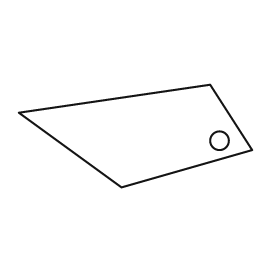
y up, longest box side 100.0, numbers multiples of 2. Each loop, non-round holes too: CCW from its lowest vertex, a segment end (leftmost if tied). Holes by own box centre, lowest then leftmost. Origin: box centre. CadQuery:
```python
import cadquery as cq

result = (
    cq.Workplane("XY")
    .moveTo(-6.0, -22.0)
    .lineTo(50.0, -6.0)
    .lineTo(32.0, 22.0)
    .lineTo(-50.0, 10.0)
    .close()
    .moveTo(36.0, -2.0)
    .circle(4.0)
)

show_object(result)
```